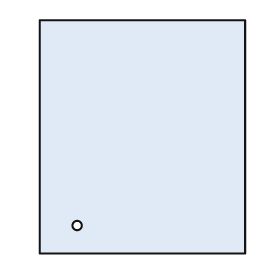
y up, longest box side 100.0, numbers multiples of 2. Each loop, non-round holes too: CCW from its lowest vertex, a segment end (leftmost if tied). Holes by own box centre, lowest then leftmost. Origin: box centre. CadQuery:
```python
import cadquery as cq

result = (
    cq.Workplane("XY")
    .moveTo(-44.0, -50.0)
    .lineTo(44.0, -50.0)
    .lineTo(44.0, 50.0)
    .lineTo(-44.0, 50.0)
    .close()
    .moveTo(-28.0, -38.0)
    .circle(2.0)
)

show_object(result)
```